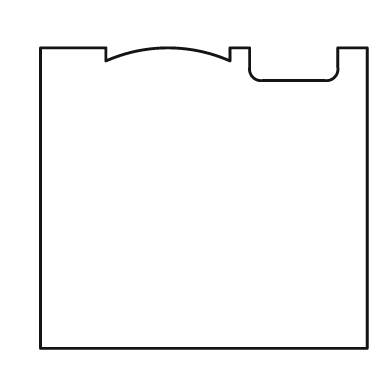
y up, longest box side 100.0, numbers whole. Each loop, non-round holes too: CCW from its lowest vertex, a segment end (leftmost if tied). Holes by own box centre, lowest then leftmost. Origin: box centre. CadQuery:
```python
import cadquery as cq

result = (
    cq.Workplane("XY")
    .moveTo(-50.0, -46.0)
    .lineTo(50.0, -46.0)
    .lineTo(50.0, 46.0)
    .lineTo(41.0, 46.0)
    .lineTo(41.0, 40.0)
    .threePointArc((40.0, 37.0), (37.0, 36.0))
    .lineTo(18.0, 36.0)
    .threePointArc((15.0, 37.0), (14.0, 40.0))
    .lineTo(14.0, 46.0)
    .lineTo(8.0, 46.0)
    .lineTo(8.0, 42.0)
    .threePointArc((-11.0, 46.0), (-30.0, 42.0))
    .lineTo(-30.0, 46.0)
    .lineTo(-50.0, 46.0)
    .close()
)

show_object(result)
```